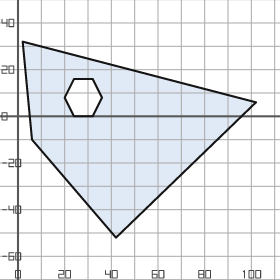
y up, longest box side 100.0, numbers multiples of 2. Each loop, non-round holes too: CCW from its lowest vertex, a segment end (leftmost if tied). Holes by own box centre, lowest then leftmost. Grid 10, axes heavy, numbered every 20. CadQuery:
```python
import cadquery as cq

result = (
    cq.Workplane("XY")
    .moveTo(42.0, -52.0)
    .lineTo(102.0, 6.0)
    .lineTo(2.0, 32.0)
    .lineTo(6.0, -10.0)
    .close()
    .moveTo(24.0, 0.0)
    .lineTo(32.0, 0.0)
    .lineTo(36.0, 8.0)
    .lineTo(32.0, 16.0)
    .lineTo(24.0, 16.0)
    .lineTo(20.0, 8.0)
    .close()
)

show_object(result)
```